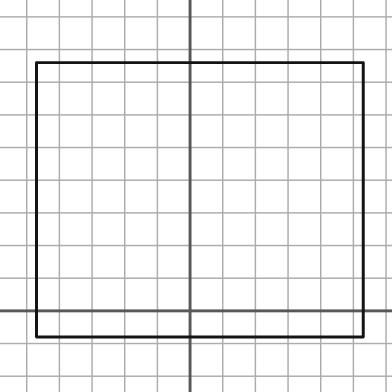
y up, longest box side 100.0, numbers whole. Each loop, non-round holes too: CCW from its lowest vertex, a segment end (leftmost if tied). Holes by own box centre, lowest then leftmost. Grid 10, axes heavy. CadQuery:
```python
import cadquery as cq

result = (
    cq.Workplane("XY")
    .moveTo(-47.0, -8.0)
    .lineTo(53.0, -8.0)
    .lineTo(53.0, 76.0)
    .lineTo(-47.0, 76.0)
    .close()
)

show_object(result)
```